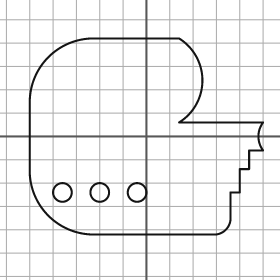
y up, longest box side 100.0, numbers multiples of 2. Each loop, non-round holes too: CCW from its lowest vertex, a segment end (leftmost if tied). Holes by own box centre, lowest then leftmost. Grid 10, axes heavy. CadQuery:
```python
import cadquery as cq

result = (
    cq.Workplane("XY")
    .moveTo(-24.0, -42.0)
    .lineTo(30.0, -42.0)
    .threePointArc((34.0, -40.0), (36.0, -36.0))
    .lineTo(36.0, -24.0)
    .lineTo(40.0, -24.0)
    .lineTo(40.0, -14.0)
    .lineTo(44.0, -14.0)
    .lineTo(44.0, -6.0)
    .lineTo(50.0, -6.0)
    .threePointArc((48.0, 0.0), (50.0, 6.0))
    .lineTo(14.0, 6.0)
    .threePointArc((24.0, 24.0), (14.0, 42.0))
    .lineTo(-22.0, 42.0)
    .threePointArc((-42.0, 34.0), (-50.0, 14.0))
    .lineTo(-50.0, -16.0)
    .threePointArc((-42.0, -34.0), (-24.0, -42.0))
    .close()
    .moveTo(-36.0, -24.0)
    .circle(4.0)
    .moveTo(-20.0, -24.0)
    .circle(4.0)
    .moveTo(-4.0, -24.0)
    .circle(4.0)
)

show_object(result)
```